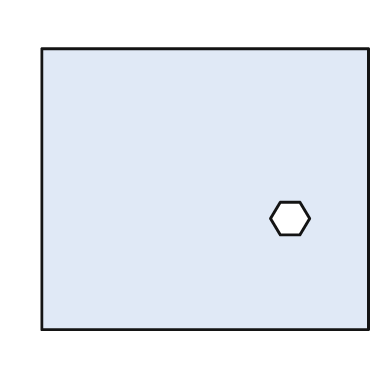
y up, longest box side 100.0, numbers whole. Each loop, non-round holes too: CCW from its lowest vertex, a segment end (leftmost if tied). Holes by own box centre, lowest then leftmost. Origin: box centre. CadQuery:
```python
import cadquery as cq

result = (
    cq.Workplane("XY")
    .moveTo(-50.0, -43.0)
    .lineTo(50.0, -43.0)
    .lineTo(50.0, 43.0)
    .lineTo(-50.0, 43.0)
    .close()
    .moveTo(23.0, -14.0)
    .lineTo(29.0, -14.0)
    .lineTo(32.0, -9.0)
    .lineTo(29.0, -4.0)
    .lineTo(23.0, -4.0)
    .lineTo(20.0, -9.0)
    .close()
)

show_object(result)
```